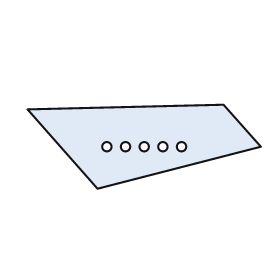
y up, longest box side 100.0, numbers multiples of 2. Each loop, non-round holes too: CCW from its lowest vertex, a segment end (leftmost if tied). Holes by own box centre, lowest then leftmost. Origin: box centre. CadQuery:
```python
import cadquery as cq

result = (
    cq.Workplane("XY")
    .moveTo(-20.0, -18.0)
    .lineTo(50.0, 0.0)
    .lineTo(34.0, 18.0)
    .lineTo(-50.0, 16.0)
    .close()
    .moveTo(-16.0, 0.0)
    .circle(2.0)
    .moveTo(-8.0, 0.0)
    .circle(2.0)
    .moveTo(0.0, 0.0)
    .circle(2.0)
    .moveTo(8.0, 0.0)
    .circle(2.0)
    .moveTo(16.0, 0.0)
    .circle(2.0)
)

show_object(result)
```